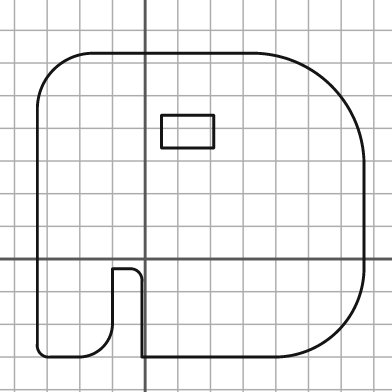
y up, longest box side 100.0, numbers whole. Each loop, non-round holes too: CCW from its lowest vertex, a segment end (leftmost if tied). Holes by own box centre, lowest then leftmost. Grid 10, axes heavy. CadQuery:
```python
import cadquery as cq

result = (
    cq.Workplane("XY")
    .moveTo(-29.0, -30.0)
    .lineTo(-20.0, -30.0)
    .threePointArc((-13.0, -27.0), (-10.0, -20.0))
    .lineTo(-10.0, -3.0)
    .lineTo(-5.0, -3.0)
    .threePointArc((-2.0, -4.0), (-1.0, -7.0))
    .lineTo(-1.0, -30.0)
    .lineTo(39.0, -30.0)
    .threePointArc((59.0, -22.0), (67.0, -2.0))
    .lineTo(67.0, 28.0)
    .threePointArc((57.0, 53.0), (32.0, 63.0))
    .lineTo(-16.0, 63.0)
    .threePointArc((-28.0, 58.0), (-33.0, 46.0))
    .lineTo(-33.0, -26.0)
    .threePointArc((-32.0, -29.0), (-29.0, -30.0))
    .close()
    .moveTo(5.0, 34.0)
    .lineTo(21.0, 34.0)
    .lineTo(21.0, 44.0)
    .lineTo(5.0, 44.0)
    .close()
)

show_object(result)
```